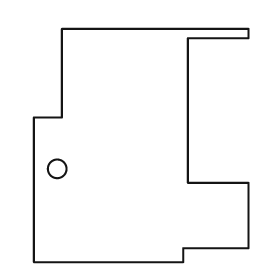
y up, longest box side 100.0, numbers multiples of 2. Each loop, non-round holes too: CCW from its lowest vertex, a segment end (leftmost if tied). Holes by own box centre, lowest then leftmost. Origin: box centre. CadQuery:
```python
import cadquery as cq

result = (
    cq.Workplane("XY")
    .moveTo(-46.0, -50.0)
    .lineTo(18.0, -50.0)
    .lineTo(18.0, -44.0)
    .lineTo(46.0, -44.0)
    .lineTo(46.0, -16.0)
    .lineTo(20.0, -16.0)
    .lineTo(20.0, 46.0)
    .lineTo(46.0, 46.0)
    .lineTo(46.0, 50.0)
    .lineTo(-34.0, 50.0)
    .lineTo(-34.0, 12.0)
    .lineTo(-46.0, 12.0)
    .close()
    .moveTo(-36.0, -10.0)
    .circle(4.0)
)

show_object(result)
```